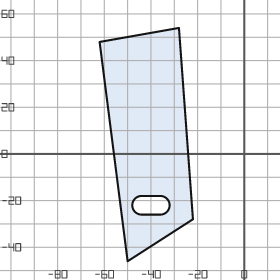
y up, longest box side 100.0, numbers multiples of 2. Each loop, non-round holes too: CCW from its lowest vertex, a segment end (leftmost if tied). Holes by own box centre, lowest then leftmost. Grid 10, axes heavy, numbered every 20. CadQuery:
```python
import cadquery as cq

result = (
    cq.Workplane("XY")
    .moveTo(-50.0, -46.0)
    .lineTo(-22.0, -28.0)
    .lineTo(-28.0, 54.0)
    .lineTo(-62.0, 48.0)
    .close()
    .moveTo(-44.0, -26.0)
    .lineTo(-36.0, -26.0)
    .threePointArc((-32.0, -22.0), (-36.0, -18.0))
    .lineTo(-44.0, -18.0)
    .threePointArc((-48.0, -22.0), (-44.0, -26.0))
    .close()
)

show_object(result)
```